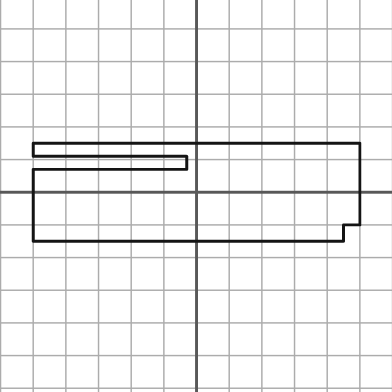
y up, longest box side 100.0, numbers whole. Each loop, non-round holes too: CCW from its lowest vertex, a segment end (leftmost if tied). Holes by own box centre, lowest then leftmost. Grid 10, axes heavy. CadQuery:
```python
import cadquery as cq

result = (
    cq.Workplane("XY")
    .moveTo(-50.0, -15.0)
    .lineTo(45.0, -15.0)
    .lineTo(45.0, -10.0)
    .lineTo(50.0, -10.0)
    .lineTo(50.0, 15.0)
    .lineTo(-50.0, 15.0)
    .lineTo(-50.0, 11.0)
    .lineTo(-3.0, 11.0)
    .lineTo(-3.0, 7.0)
    .lineTo(-50.0, 7.0)
    .close()
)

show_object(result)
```